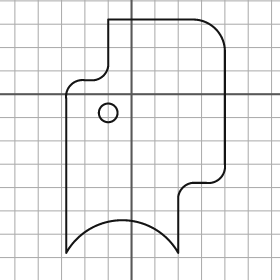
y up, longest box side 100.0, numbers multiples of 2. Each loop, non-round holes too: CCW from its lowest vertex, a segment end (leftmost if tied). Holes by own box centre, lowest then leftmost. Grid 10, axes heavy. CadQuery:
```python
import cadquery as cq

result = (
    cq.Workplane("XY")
    .moveTo(-28.0, -68.0)
    .threePointArc((-4.0, -54.0), (20.0, -68.0))
    .lineTo(20.0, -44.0)
    .threePointArc((22.0, -40.0), (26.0, -38.0))
    .lineTo(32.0, -38.0)
    .threePointArc((38.0, -36.0), (40.0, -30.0))
    .lineTo(40.0, 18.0)
    .threePointArc((36.0, 28.0), (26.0, 32.0))
    .lineTo(-10.0, 32.0)
    .lineTo(-10.0, 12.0)
    .threePointArc((-12.0, 8.0), (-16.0, 6.0))
    .lineTo(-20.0, 6.0)
    .threePointArc((-26.0, 4.0), (-28.0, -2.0))
    .close()
    .moveTo(-10.0, -8.0)
    .circle(4.0)
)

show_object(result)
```